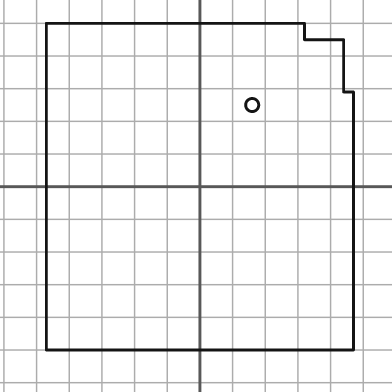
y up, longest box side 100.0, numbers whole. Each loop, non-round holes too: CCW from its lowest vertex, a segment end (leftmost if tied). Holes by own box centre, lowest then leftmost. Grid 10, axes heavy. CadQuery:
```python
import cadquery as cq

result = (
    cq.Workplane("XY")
    .moveTo(-47.0, -50.0)
    .lineTo(47.0, -50.0)
    .lineTo(47.0, 29.0)
    .lineTo(44.0, 29.0)
    .lineTo(44.0, 45.0)
    .lineTo(32.0, 45.0)
    .lineTo(32.0, 50.0)
    .lineTo(-47.0, 50.0)
    .close()
    .moveTo(16.0, 25.0)
    .circle(2.0)
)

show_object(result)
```